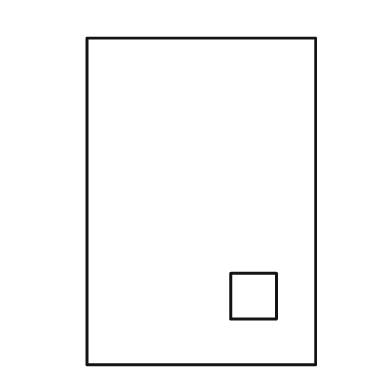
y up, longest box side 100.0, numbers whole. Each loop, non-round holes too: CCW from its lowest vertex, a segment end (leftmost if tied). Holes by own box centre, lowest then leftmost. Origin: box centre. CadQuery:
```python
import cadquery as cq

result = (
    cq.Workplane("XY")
    .moveTo(-35.0, -50.0)
    .lineTo(35.0, -50.0)
    .lineTo(35.0, 50.0)
    .lineTo(-35.0, 50.0)
    .close()
    .moveTo(9.0, -36.0)
    .lineTo(23.0, -36.0)
    .lineTo(23.0, -22.0)
    .lineTo(9.0, -22.0)
    .close()
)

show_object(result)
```